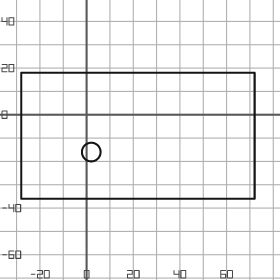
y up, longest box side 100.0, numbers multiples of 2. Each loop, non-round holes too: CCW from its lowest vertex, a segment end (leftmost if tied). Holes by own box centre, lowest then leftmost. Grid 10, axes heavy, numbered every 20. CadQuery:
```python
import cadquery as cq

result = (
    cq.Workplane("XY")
    .moveTo(-28.0, -36.0)
    .lineTo(72.0, -36.0)
    .lineTo(72.0, 18.0)
    .lineTo(-28.0, 18.0)
    .close()
    .moveTo(2.0, -16.0)
    .circle(4.0)
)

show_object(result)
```